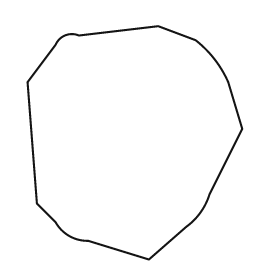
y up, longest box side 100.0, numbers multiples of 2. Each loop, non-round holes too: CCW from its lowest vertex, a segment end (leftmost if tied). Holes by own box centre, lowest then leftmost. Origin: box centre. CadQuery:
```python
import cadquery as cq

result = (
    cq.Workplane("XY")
    .moveTo(6.0, -50.0)
    .lineTo(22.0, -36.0)
    .threePointArc((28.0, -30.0), (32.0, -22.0))
    .lineTo(46.0, 6.0)
    .lineTo(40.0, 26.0)
    .threePointArc((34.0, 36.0), (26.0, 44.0))
    .lineTo(10.0, 50.0)
    .lineTo(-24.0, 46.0)
    .threePointArc((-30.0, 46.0), (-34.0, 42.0))
    .lineTo(-46.0, 26.0)
    .lineTo(-42.0, -26.0)
    .lineTo(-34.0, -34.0)
    .threePointArc((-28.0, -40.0), (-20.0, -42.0))
    .close()
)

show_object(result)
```